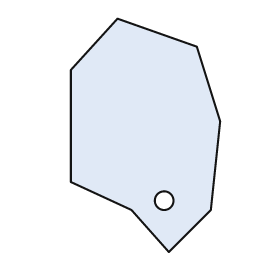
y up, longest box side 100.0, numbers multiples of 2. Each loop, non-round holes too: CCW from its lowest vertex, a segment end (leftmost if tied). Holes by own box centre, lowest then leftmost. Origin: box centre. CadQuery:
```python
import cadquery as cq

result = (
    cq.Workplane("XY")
    .moveTo(10.0, -50.0)
    .lineTo(28.0, -32.0)
    .lineTo(32.0, 6.0)
    .lineTo(22.0, 38.0)
    .lineTo(-12.0, 50.0)
    .lineTo(-32.0, 28.0)
    .lineTo(-32.0, -20.0)
    .lineTo(-6.0, -32.0)
    .close()
    .moveTo(8.0, -28.0)
    .circle(4.0)
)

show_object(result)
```